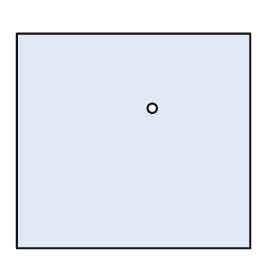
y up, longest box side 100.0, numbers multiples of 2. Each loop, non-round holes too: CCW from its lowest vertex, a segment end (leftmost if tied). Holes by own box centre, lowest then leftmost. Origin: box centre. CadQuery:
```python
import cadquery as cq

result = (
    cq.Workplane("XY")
    .moveTo(-50.0, -46.0)
    .lineTo(50.0, -46.0)
    .lineTo(50.0, 46.0)
    .lineTo(-50.0, 46.0)
    .close()
    .moveTo(8.0, 14.0)
    .circle(2.0)
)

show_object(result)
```